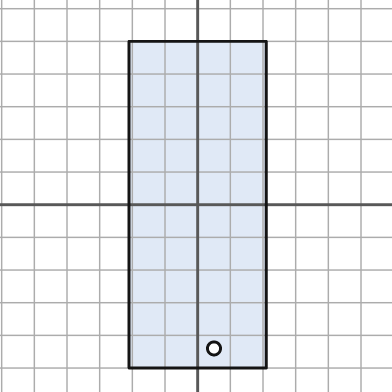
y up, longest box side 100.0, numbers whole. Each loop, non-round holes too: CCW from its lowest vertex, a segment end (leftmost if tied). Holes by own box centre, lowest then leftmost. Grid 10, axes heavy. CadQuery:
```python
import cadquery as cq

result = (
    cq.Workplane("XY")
    .moveTo(-21.0, -50.0)
    .lineTo(21.0, -50.0)
    .lineTo(21.0, 50.0)
    .lineTo(-21.0, 50.0)
    .close()
    .moveTo(5.0, -44.0)
    .circle(2.0)
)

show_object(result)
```